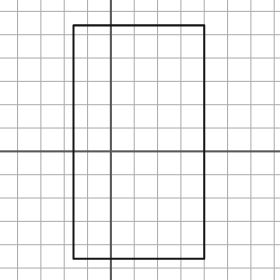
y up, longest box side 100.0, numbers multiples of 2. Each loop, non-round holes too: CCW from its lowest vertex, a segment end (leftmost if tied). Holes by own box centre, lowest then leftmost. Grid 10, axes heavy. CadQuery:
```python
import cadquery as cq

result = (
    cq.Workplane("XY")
    .moveTo(-16.0, -46.0)
    .lineTo(40.0, -46.0)
    .lineTo(40.0, 54.0)
    .lineTo(-16.0, 54.0)
    .close()
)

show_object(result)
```